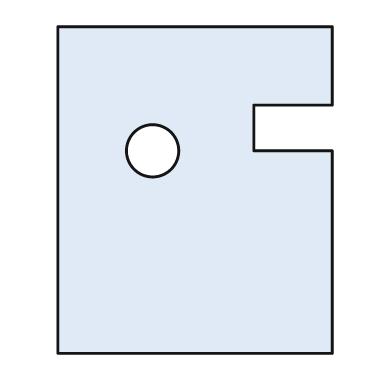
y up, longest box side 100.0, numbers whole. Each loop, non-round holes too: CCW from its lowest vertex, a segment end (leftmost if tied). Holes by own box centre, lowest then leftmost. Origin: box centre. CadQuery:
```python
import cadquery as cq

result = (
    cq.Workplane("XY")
    .moveTo(-42.0, -50.0)
    .lineTo(42.0, -50.0)
    .lineTo(42.0, 12.0)
    .lineTo(18.0, 12.0)
    .lineTo(18.0, 26.0)
    .lineTo(42.0, 26.0)
    .lineTo(42.0, 50.0)
    .lineTo(-42.0, 50.0)
    .close()
    .moveTo(-13.0, 12.0)
    .circle(8.0)
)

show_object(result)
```